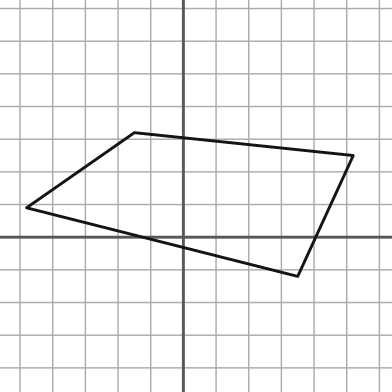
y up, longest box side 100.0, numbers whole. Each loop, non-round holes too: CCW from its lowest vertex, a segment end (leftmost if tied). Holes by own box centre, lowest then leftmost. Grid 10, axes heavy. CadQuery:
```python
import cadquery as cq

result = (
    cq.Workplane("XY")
    .moveTo(35.0, -12.0)
    .lineTo(52.0, 25.0)
    .lineTo(-15.0, 32.0)
    .lineTo(-48.0, 9.0)
    .close()
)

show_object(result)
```